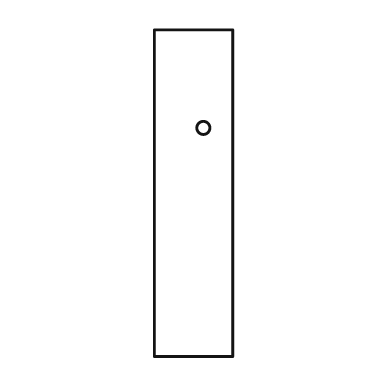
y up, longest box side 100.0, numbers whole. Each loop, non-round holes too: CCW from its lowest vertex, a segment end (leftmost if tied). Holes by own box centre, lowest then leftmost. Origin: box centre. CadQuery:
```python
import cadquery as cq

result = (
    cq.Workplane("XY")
    .moveTo(-12.0, -50.0)
    .lineTo(12.0, -50.0)
    .lineTo(12.0, 50.0)
    .lineTo(-12.0, 50.0)
    .close()
    .moveTo(3.0, 20.0)
    .circle(2.0)
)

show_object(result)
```